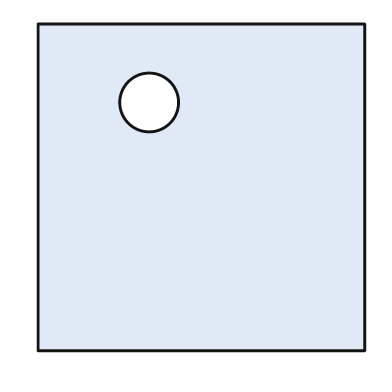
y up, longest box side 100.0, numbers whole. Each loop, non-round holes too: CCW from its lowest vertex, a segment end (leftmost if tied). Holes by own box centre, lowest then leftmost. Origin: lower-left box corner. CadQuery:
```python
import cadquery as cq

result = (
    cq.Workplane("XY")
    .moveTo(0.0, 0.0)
    .lineTo(100.0, 0.0)
    .lineTo(100.0, 100.0)
    .lineTo(0.0, 100.0)
    .close()
    .moveTo(34.0, 76.0)
    .circle(9.0)
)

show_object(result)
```